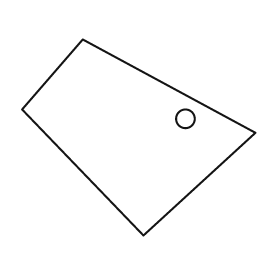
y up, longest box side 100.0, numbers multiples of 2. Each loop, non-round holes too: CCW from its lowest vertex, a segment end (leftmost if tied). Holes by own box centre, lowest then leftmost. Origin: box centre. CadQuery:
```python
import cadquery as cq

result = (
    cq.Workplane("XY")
    .moveTo(2.0, -42.0)
    .lineTo(50.0, 2.0)
    .lineTo(-24.0, 42.0)
    .lineTo(-50.0, 12.0)
    .close()
    .moveTo(20.0, 8.0)
    .circle(4.0)
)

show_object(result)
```